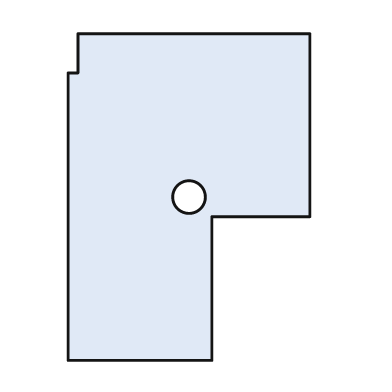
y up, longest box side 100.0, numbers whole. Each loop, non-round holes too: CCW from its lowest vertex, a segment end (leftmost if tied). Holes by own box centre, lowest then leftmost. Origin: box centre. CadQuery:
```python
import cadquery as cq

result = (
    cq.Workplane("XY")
    .moveTo(-37.0, -50.0)
    .lineTo(7.0, -50.0)
    .lineTo(7.0, -6.0)
    .lineTo(37.0, -6.0)
    .lineTo(37.0, 50.0)
    .lineTo(-34.0, 50.0)
    .lineTo(-34.0, 38.0)
    .lineTo(-37.0, 38.0)
    .close()
    .moveTo(0.0, 0.0)
    .circle(5.0)
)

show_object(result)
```